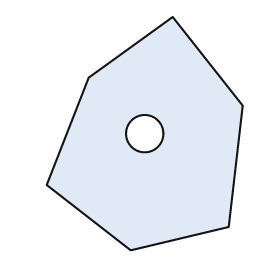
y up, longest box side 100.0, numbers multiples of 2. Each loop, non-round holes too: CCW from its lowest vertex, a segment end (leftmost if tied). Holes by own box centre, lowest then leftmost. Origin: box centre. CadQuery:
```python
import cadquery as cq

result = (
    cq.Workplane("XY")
    .moveTo(-6.0, -50.0)
    .lineTo(36.0, -40.0)
    .lineTo(42.0, 12.0)
    .lineTo(12.0, 50.0)
    .lineTo(-24.0, 24.0)
    .lineTo(-42.0, -22.0)
    .close()
    .moveTo(0.0, 0.0)
    .circle(8.0)
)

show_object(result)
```